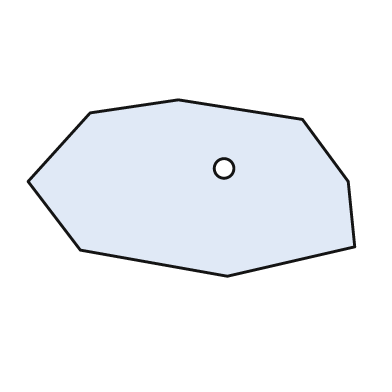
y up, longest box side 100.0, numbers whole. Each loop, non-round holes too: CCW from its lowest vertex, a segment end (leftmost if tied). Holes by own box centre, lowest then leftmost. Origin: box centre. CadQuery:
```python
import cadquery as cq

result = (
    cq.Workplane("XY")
    .moveTo(11.0, -27.0)
    .lineTo(50.0, -18.0)
    .lineTo(48.0, 2.0)
    .lineTo(34.0, 21.0)
    .lineTo(-4.0, 27.0)
    .lineTo(-31.0, 23.0)
    .lineTo(-50.0, 2.0)
    .lineTo(-34.0, -19.0)
    .close()
    .moveTo(10.0, 6.0)
    .circle(3.0)
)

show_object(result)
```